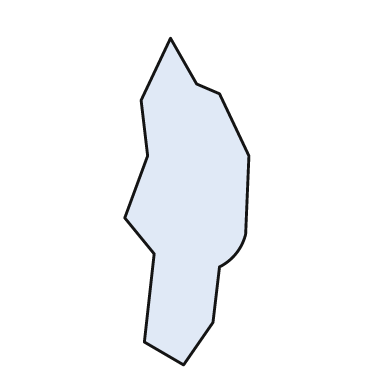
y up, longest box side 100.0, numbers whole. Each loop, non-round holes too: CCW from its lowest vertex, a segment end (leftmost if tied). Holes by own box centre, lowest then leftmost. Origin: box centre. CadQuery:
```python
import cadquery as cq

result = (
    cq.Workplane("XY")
    .moveTo(-1.0, -50.0)
    .lineTo(8.0, -37.0)
    .lineTo(10.0, -20.0)
    .threePointArc((15.0, -16.0), (18.0, -10.0))
    .lineTo(19.0, 14.0)
    .lineTo(10.0, 33.0)
    .lineTo(3.0, 36.0)
    .lineTo(-5.0, 50.0)
    .lineTo(-14.0, 31.0)
    .lineTo(-12.0, 14.0)
    .lineTo(-19.0, -5.0)
    .lineTo(-10.0, -16.0)
    .lineTo(-13.0, -43.0)
    .close()
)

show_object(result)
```